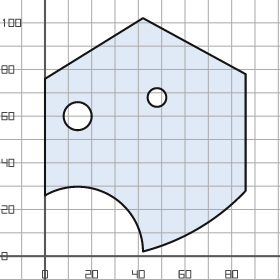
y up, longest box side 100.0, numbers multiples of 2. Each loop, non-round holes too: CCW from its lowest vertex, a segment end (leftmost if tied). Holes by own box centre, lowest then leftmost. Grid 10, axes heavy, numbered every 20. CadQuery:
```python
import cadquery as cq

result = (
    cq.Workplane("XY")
    .moveTo(42.0, 2.0)
    .threePointArc((66.0, 12.0), (86.0, 28.0))
    .lineTo(86.0, 78.0)
    .lineTo(42.0, 102.0)
    .lineTo(0.0, 76.0)
    .lineTo(0.0, 26.0)
    .threePointArc((28.0, 26.0), (42.0, 2.0))
    .close()
    .moveTo(14.0, 60.0)
    .circle(6.0)
    .moveTo(48.0, 68.0)
    .circle(4.0)
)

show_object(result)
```